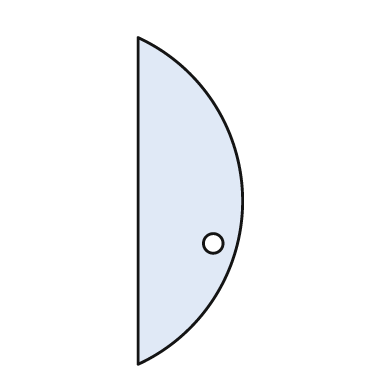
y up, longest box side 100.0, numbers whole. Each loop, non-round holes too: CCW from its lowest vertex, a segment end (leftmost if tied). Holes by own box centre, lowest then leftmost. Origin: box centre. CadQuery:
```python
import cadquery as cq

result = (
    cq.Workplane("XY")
    .moveTo(-16.0, -50.0)
    .threePointArc((16.0, 0.0), (-16.0, 50.0))
    .close()
    .moveTo(7.0, -13.0)
    .circle(3.0)
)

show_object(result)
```